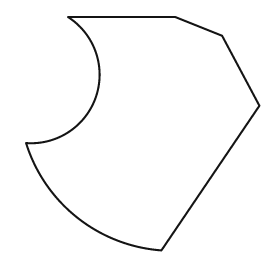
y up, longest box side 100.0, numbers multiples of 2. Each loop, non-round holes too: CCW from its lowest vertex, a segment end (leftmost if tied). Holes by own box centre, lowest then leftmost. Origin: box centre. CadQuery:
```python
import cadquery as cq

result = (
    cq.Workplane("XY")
    .moveTo(8.0, -50.0)
    .lineTo(50.0, 12.0)
    .lineTo(34.0, 42.0)
    .lineTo(14.0, 50.0)
    .lineTo(-32.0, 50.0)
    .threePointArc((-20.0, 16.0), (-50.0, -4.0))
    .threePointArc((-28.0, -36.0), (8.0, -50.0))
    .close()
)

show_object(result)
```